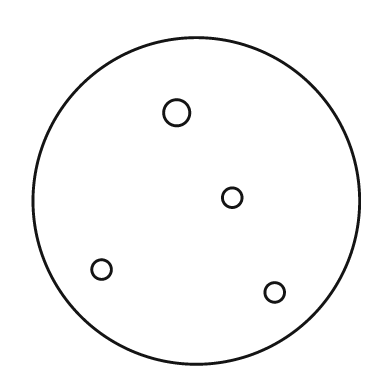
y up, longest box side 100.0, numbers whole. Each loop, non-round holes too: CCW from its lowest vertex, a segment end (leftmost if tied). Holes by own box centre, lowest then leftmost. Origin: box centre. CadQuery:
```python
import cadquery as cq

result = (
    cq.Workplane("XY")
    .moveTo(0.0, 0.0)
    .circle(50.0)
    .moveTo(24.0, -28.0)
    .circle(3.0)
    .moveTo(-29.0, -21.0)
    .circle(3.0)
    .moveTo(11.0, 1.0)
    .circle(3.0)
    .moveTo(-6.0, 27.0)
    .circle(4.0)
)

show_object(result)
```